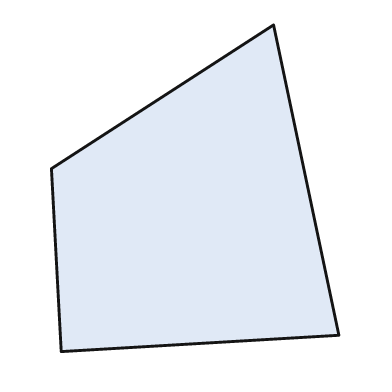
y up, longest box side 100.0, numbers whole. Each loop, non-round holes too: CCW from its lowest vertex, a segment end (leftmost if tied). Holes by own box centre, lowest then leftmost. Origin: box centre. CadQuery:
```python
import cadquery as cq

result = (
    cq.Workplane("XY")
    .moveTo(-41.0, -50.0)
    .lineTo(44.0, -45.0)
    .lineTo(24.0, 50.0)
    .lineTo(-44.0, 6.0)
    .close()
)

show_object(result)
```